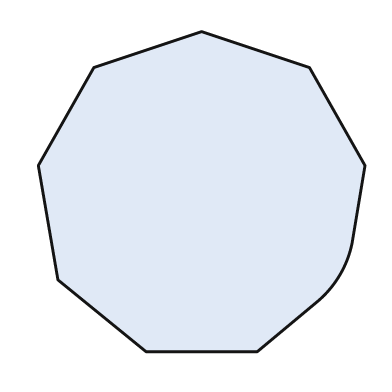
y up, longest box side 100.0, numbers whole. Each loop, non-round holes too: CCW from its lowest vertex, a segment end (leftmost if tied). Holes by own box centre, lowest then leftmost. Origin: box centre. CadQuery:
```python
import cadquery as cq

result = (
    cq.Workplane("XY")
    .moveTo(-17.0, -49.0)
    .lineTo(17.0, -49.0)
    .lineTo(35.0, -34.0)
    .threePointArc((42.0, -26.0), (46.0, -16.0))
    .lineTo(50.0, 8.0)
    .lineTo(33.0, 38.0)
    .lineTo(0.0, 49.0)
    .lineTo(-33.0, 38.0)
    .lineTo(-50.0, 8.0)
    .lineTo(-44.0, -27.0)
    .close()
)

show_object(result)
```